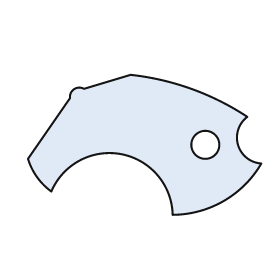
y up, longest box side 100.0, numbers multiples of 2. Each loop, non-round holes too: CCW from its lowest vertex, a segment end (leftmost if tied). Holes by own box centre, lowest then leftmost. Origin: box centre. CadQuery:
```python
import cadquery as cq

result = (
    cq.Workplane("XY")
    .moveTo(12.0, -30.0)
    .threePointArc((34.0, -24.0), (50.0, -8.0))
    .threePointArc((40.0, 0.0), (44.0, 12.0))
    .threePointArc((20.0, 24.0), (-6.0, 30.0))
    .lineTo(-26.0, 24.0)
    .threePointArc((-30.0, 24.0), (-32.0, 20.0))
    .lineTo(-50.0, -6.0)
    .threePointArc((-46.0, -14.0), (-40.0, -20.0))
    .threePointArc((-10.0, -4.0), (12.0, -30.0))
    .close()
    .moveTo(26.0, 0.0)
    .circle(6.0)
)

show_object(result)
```